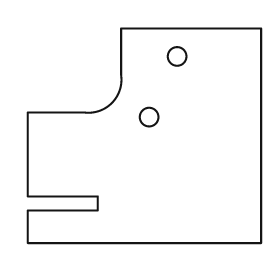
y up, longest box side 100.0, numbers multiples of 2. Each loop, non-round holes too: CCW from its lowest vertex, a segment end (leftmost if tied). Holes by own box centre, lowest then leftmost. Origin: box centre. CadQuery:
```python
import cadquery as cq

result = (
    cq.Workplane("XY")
    .moveTo(-50.0, -46.0)
    .lineTo(50.0, -46.0)
    .lineTo(50.0, 46.0)
    .lineTo(-10.0, 46.0)
    .lineTo(-10.0, 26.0)
    .threePointArc((-14.0, 14.0), (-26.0, 10.0))
    .lineTo(-50.0, 10.0)
    .lineTo(-50.0, -26.0)
    .lineTo(-20.0, -26.0)
    .lineTo(-20.0, -32.0)
    .lineTo(-50.0, -32.0)
    .close()
    .moveTo(2.0, 8.0)
    .circle(4.0)
    .moveTo(14.0, 34.0)
    .circle(4.0)
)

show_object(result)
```